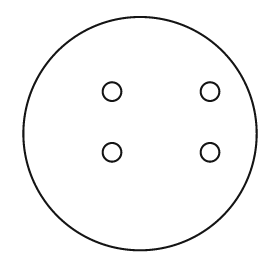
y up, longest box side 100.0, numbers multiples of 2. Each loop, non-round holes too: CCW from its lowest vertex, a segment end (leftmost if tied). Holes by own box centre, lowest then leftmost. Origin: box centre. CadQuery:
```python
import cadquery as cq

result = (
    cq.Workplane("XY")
    .moveTo(0.0, 0.0)
    .circle(50.0)
    .moveTo(-12.0, -8.0)
    .circle(4.0)
    .moveTo(30.0, -8.0)
    .circle(4.0)
    .moveTo(-12.0, 18.0)
    .circle(4.0)
    .moveTo(30.0, 18.0)
    .circle(4.0)
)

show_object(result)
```